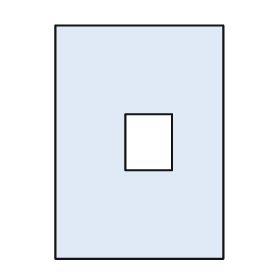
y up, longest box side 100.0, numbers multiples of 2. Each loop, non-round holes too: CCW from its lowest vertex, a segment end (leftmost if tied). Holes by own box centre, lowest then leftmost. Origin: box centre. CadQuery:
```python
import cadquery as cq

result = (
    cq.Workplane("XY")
    .moveTo(-36.0, -50.0)
    .lineTo(36.0, -50.0)
    .lineTo(36.0, 50.0)
    .lineTo(-36.0, 50.0)
    .close()
    .moveTo(-6.0, -12.0)
    .lineTo(14.0, -12.0)
    .lineTo(14.0, 12.0)
    .lineTo(-6.0, 12.0)
    .close()
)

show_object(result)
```